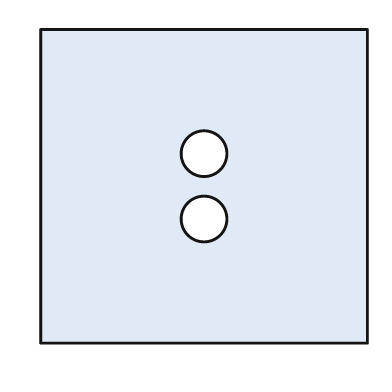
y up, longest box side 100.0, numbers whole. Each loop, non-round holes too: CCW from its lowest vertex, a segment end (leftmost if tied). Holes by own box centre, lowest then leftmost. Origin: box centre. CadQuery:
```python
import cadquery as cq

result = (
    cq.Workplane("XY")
    .moveTo(-50.0, -48.0)
    .lineTo(50.0, -48.0)
    .lineTo(50.0, 48.0)
    .lineTo(-50.0, 48.0)
    .close()
    .moveTo(0.0, -10.0)
    .circle(7.0)
    .moveTo(0.0, 10.0)
    .circle(7.0)
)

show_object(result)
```